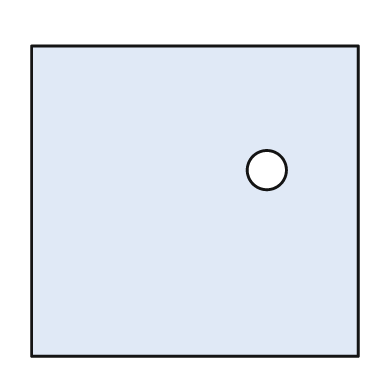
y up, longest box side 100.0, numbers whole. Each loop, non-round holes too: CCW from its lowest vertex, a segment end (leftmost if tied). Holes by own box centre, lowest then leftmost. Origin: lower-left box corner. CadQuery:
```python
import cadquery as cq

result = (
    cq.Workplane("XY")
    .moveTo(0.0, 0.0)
    .lineTo(100.0, 0.0)
    .lineTo(100.0, 95.0)
    .lineTo(0.0, 95.0)
    .close()
    .moveTo(72.0, 57.0)
    .circle(6.0)
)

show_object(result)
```